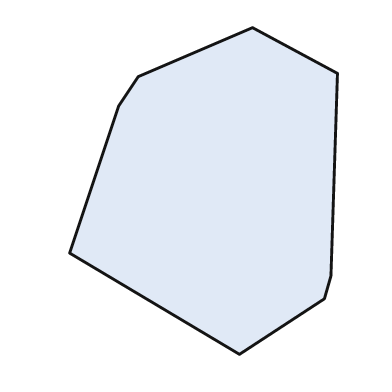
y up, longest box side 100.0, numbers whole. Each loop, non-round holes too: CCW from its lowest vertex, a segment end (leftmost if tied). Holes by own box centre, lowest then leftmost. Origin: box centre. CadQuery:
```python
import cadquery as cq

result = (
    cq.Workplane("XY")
    .moveTo(11.0, -50.0)
    .lineTo(37.0, -33.0)
    .lineTo(39.0, -26.0)
    .lineTo(41.0, 36.0)
    .lineTo(15.0, 50.0)
    .lineTo(-20.0, 35.0)
    .lineTo(-26.0, 26.0)
    .lineTo(-41.0, -19.0)
    .close()
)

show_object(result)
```